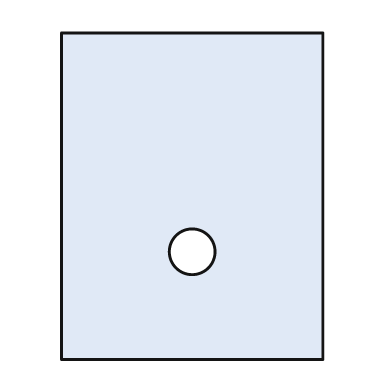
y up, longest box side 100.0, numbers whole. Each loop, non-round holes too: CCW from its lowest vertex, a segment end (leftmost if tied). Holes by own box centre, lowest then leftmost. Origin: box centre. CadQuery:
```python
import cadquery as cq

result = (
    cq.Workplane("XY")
    .moveTo(-40.0, -50.0)
    .lineTo(40.0, -50.0)
    .lineTo(40.0, 50.0)
    .lineTo(-40.0, 50.0)
    .close()
    .moveTo(0.0, -17.0)
    .circle(7.0)
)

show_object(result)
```